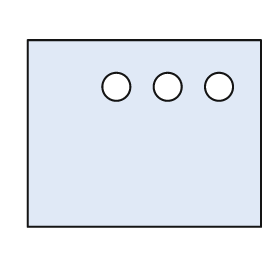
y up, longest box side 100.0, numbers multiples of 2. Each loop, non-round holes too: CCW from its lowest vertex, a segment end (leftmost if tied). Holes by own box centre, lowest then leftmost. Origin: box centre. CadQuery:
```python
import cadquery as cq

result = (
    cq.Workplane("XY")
    .moveTo(-50.0, -40.0)
    .lineTo(50.0, -40.0)
    .lineTo(50.0, 40.0)
    .lineTo(-50.0, 40.0)
    .close()
    .moveTo(-12.0, 20.0)
    .circle(6.0)
    .moveTo(10.0, 20.0)
    .circle(6.0)
    .moveTo(32.0, 20.0)
    .circle(6.0)
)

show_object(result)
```